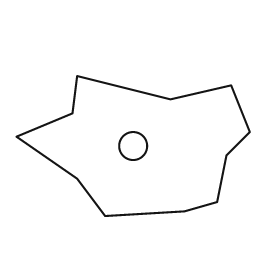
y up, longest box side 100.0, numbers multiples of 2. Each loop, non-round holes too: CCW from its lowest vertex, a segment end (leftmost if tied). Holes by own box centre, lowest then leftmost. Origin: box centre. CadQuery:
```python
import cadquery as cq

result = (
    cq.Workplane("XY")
    .moveTo(-12.0, -30.0)
    .lineTo(22.0, -28.0)
    .lineTo(36.0, -24.0)
    .lineTo(40.0, -4.0)
    .lineTo(50.0, 6.0)
    .lineTo(42.0, 26.0)
    .lineTo(16.0, 20.0)
    .lineTo(-24.0, 30.0)
    .lineTo(-26.0, 14.0)
    .lineTo(-50.0, 4.0)
    .lineTo(-24.0, -14.0)
    .close()
    .moveTo(0.0, 0.0)
    .circle(6.0)
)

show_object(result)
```